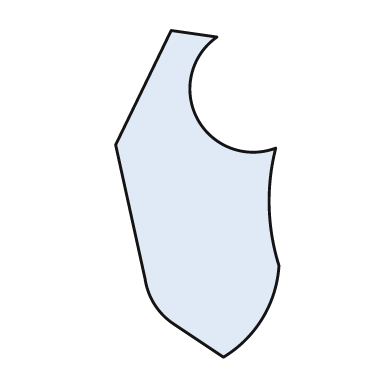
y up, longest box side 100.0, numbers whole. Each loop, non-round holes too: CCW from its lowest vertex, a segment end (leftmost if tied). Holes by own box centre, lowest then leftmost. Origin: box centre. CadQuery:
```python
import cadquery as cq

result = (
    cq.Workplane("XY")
    .moveTo(8.0, -50.0)
    .threePointArc((20.0, -38.0), (25.0, -22.0))
    .threePointArc((22.0, -4.0), (24.0, 14.0))
    .threePointArc((0.0, 23.0), (6.0, 48.0))
    .lineTo(-8.0, 50.0)
    .lineTo(-25.0, 15.0)
    .lineTo(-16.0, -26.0)
    .threePointArc((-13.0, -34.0), (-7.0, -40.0))
    .close()
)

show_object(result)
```